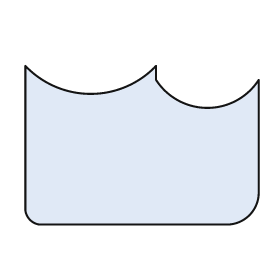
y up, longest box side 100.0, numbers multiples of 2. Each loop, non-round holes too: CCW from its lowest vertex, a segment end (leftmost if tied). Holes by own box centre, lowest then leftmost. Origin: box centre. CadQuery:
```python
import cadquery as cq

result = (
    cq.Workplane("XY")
    .moveTo(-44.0, -34.0)
    .lineTo(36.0, -34.0)
    .threePointArc((46.0, -30.0), (50.0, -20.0))
    .lineTo(50.0, 28.0)
    .threePointArc((28.0, 16.0), (6.0, 28.0))
    .lineTo(6.0, 34.0)
    .threePointArc((-22.0, 22.0), (-50.0, 34.0))
    .lineTo(-50.0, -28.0)
    .threePointArc((-48.0, -32.0), (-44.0, -34.0))
    .close()
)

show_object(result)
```